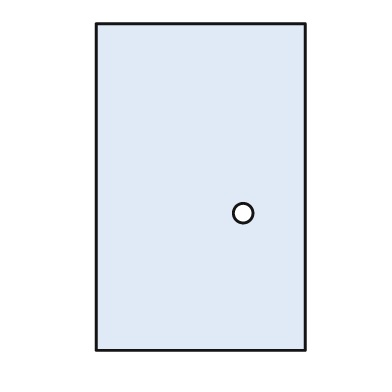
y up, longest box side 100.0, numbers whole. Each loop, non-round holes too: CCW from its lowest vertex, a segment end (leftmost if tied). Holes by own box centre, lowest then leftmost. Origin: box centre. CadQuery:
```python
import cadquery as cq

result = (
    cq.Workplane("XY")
    .moveTo(-32.0, -50.0)
    .lineTo(32.0, -50.0)
    .lineTo(32.0, 50.0)
    .lineTo(-32.0, 50.0)
    .close()
    .moveTo(13.0, -8.0)
    .circle(3.0)
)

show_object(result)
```